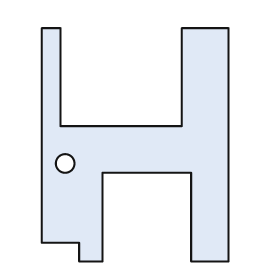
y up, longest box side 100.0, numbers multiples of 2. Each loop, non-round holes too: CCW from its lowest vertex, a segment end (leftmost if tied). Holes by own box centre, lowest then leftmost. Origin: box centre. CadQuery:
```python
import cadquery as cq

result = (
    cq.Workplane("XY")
    .moveTo(-24.0, -50.0)
    .lineTo(-14.0, -50.0)
    .lineTo(-14.0, -12.0)
    .lineTo(24.0, -12.0)
    .lineTo(24.0, -50.0)
    .lineTo(40.0, -50.0)
    .lineTo(40.0, 50.0)
    .lineTo(20.0, 50.0)
    .lineTo(20.0, 8.0)
    .lineTo(-32.0, 8.0)
    .lineTo(-32.0, 50.0)
    .lineTo(-40.0, 50.0)
    .lineTo(-40.0, -42.0)
    .lineTo(-24.0, -42.0)
    .close()
    .moveTo(-30.0, -8.0)
    .circle(4.0)
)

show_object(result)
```